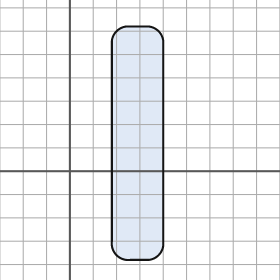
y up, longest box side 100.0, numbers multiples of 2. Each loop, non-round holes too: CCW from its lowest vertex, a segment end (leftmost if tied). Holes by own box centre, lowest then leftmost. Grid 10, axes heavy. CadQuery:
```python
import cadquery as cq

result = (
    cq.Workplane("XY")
    .moveTo(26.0, -38.0)
    .lineTo(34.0, -38.0)
    .threePointArc((38.0, -36.0), (40.0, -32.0))
    .lineTo(40.0, 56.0)
    .threePointArc((38.0, 60.0), (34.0, 62.0))
    .lineTo(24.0, 62.0)
    .threePointArc((20.0, 60.0), (18.0, 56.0))
    .lineTo(18.0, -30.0)
    .threePointArc((20.0, -36.0), (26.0, -38.0))
    .close()
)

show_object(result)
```